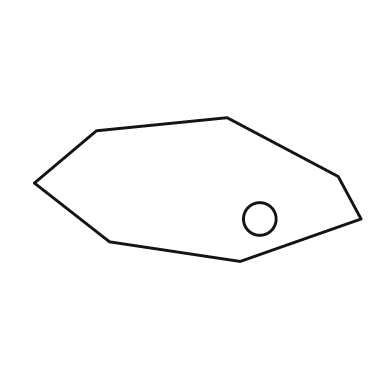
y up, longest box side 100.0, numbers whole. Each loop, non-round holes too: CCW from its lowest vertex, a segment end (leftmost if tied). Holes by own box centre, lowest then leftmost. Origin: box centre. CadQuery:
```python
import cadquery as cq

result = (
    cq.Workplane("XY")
    .moveTo(13.0, -22.0)
    .lineTo(50.0, -9.0)
    .lineTo(43.0, 4.0)
    .lineTo(9.0, 22.0)
    .lineTo(-31.0, 18.0)
    .lineTo(-50.0, 2.0)
    .lineTo(-27.0, -16.0)
    .close()
    .moveTo(19.0, -9.0)
    .circle(5.0)
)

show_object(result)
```